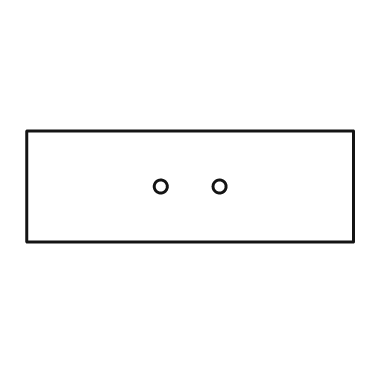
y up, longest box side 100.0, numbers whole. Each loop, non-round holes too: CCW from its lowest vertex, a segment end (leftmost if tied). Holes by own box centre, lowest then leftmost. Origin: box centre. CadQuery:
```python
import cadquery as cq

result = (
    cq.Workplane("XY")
    .moveTo(-50.0, -17.0)
    .lineTo(50.0, -17.0)
    .lineTo(50.0, 17.0)
    .lineTo(-50.0, 17.0)
    .close()
    .moveTo(-9.0, 0.0)
    .circle(2.0)
    .moveTo(9.0, 0.0)
    .circle(2.0)
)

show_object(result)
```